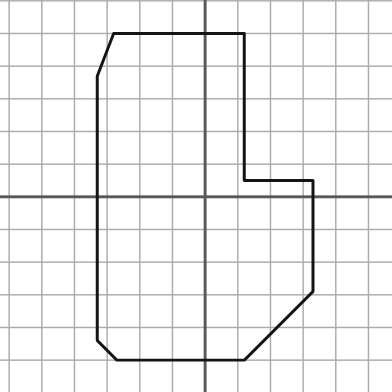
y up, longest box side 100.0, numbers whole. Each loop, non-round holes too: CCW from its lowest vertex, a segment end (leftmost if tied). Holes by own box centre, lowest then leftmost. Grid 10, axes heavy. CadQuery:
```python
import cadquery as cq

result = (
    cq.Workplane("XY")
    .moveTo(-27.0, -50.0)
    .lineTo(12.0, -50.0)
    .lineTo(33.0, -29.0)
    .lineTo(33.0, 5.0)
    .lineTo(12.0, 5.0)
    .lineTo(12.0, 50.0)
    .lineTo(-28.0, 50.0)
    .lineTo(-33.0, 37.0)
    .lineTo(-33.0, -44.0)
    .close()
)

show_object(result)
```